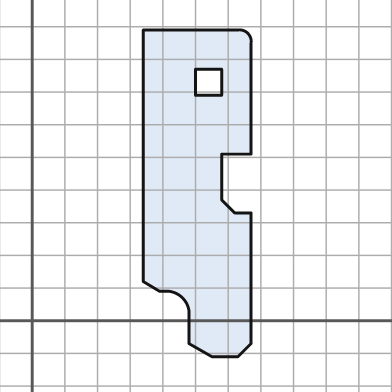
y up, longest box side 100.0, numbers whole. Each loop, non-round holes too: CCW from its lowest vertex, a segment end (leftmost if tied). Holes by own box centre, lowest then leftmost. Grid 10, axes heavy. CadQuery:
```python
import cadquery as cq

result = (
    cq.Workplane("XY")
    .moveTo(55.0, -11.0)
    .lineTo(63.0, -11.0)
    .lineTo(67.0, -7.0)
    .lineTo(67.0, 33.0)
    .lineTo(62.0, 33.0)
    .lineTo(58.0, 37.0)
    .lineTo(58.0, 51.0)
    .lineTo(67.0, 51.0)
    .lineTo(67.0, 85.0)
    .threePointArc((66.0, 88.0), (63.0, 89.0))
    .lineTo(34.0, 89.0)
    .lineTo(34.0, 12.0)
    .lineTo(39.0, 9.0)
    .lineTo(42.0, 9.0)
    .threePointArc((46.0, 7.0), (48.0, 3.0))
    .lineTo(48.0, -7.0)
    .close()
    .moveTo(50.0, 69.0)
    .lineTo(58.0, 69.0)
    .lineTo(58.0, 77.0)
    .lineTo(50.0, 77.0)
    .close()
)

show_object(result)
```